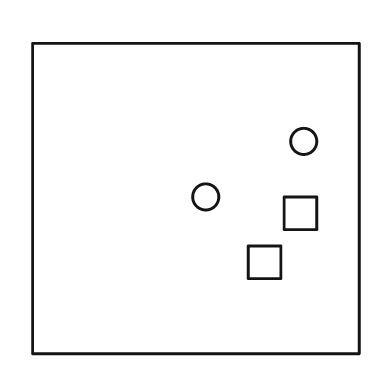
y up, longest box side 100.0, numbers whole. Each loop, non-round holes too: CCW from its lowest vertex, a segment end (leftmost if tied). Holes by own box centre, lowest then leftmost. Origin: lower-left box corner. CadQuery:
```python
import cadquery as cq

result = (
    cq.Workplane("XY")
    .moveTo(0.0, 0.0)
    .lineTo(100.0, 0.0)
    .lineTo(100.0, 95.0)
    .lineTo(0.0, 95.0)
    .close()
    .moveTo(66.0, 23.0)
    .lineTo(76.0, 23.0)
    .lineTo(76.0, 33.0)
    .lineTo(66.0, 33.0)
    .close()
    .moveTo(77.0, 38.0)
    .lineTo(87.0, 38.0)
    .lineTo(87.0, 48.0)
    .lineTo(77.0, 48.0)
    .close()
    .moveTo(53.0, 48.0)
    .circle(4.0)
    .moveTo(83.0, 65.0)
    .circle(4.0)
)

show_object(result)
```